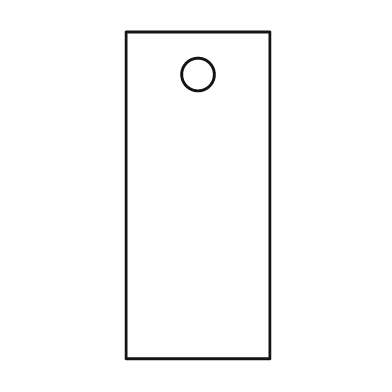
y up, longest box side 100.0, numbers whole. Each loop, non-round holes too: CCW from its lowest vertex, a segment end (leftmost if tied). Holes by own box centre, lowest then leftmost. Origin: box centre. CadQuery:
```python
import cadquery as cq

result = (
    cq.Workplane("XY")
    .moveTo(-22.0, -50.0)
    .lineTo(22.0, -50.0)
    .lineTo(22.0, 50.0)
    .lineTo(-22.0, 50.0)
    .close()
    .moveTo(0.0, 37.0)
    .circle(5.0)
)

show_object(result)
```